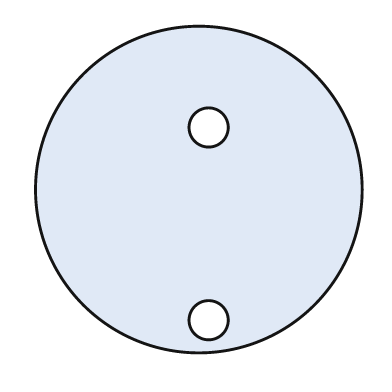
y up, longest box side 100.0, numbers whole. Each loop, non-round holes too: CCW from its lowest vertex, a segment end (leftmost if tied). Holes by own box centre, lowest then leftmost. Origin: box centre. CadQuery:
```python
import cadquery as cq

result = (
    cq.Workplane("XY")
    .moveTo(0.0, 0.0)
    .circle(50.0)
    .moveTo(3.0, -40.0)
    .circle(6.0)
    .moveTo(3.0, 19.0)
    .circle(6.0)
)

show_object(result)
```